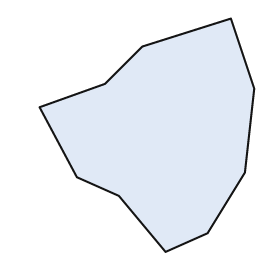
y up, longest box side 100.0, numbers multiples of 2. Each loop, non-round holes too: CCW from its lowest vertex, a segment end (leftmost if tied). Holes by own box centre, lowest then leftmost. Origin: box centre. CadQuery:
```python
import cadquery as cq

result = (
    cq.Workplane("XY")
    .moveTo(8.0, -50.0)
    .lineTo(26.0, -42.0)
    .lineTo(42.0, -16.0)
    .lineTo(46.0, 20.0)
    .lineTo(36.0, 50.0)
    .lineTo(-2.0, 38.0)
    .lineTo(-18.0, 22.0)
    .lineTo(-46.0, 12.0)
    .lineTo(-30.0, -18.0)
    .lineTo(-12.0, -26.0)
    .close()
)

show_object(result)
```